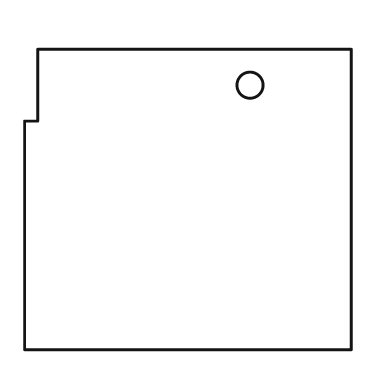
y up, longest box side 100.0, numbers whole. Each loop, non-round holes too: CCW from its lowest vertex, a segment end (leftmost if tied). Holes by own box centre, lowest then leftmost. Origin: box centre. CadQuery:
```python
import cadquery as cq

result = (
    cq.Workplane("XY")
    .moveTo(-50.0, -46.0)
    .lineTo(50.0, -46.0)
    .lineTo(50.0, 46.0)
    .lineTo(-46.0, 46.0)
    .lineTo(-46.0, 24.0)
    .lineTo(-50.0, 24.0)
    .close()
    .moveTo(19.0, 35.0)
    .circle(4.0)
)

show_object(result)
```